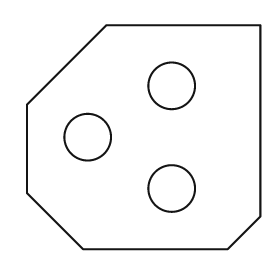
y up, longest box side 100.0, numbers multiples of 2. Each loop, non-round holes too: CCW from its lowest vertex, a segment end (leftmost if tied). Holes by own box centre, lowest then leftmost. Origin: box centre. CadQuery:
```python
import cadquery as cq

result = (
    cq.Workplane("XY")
    .moveTo(-26.0, -48.0)
    .lineTo(36.0, -48.0)
    .lineTo(50.0, -34.0)
    .lineTo(50.0, 48.0)
    .lineTo(-16.0, 48.0)
    .lineTo(-50.0, 14.0)
    .lineTo(-50.0, -24.0)
    .close()
    .moveTo(12.0, -22.0)
    .circle(10.0)
    .moveTo(-24.0, 0.0)
    .circle(10.0)
    .moveTo(12.0, 22.0)
    .circle(10.0)
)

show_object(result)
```